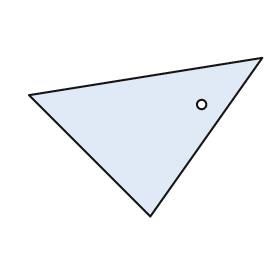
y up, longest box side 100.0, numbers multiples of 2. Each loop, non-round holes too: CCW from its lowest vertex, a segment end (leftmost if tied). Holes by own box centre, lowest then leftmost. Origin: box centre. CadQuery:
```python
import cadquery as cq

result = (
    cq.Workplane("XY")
    .moveTo(2.0, -34.0)
    .lineTo(50.0, 34.0)
    .lineTo(-50.0, 18.0)
    .close()
    .moveTo(24.0, 14.0)
    .circle(2.0)
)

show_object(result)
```